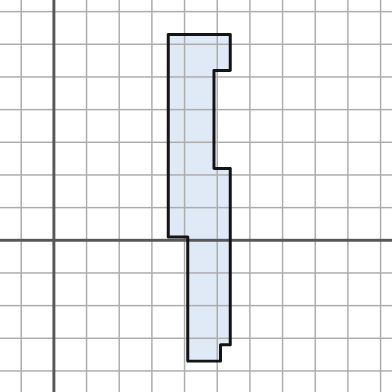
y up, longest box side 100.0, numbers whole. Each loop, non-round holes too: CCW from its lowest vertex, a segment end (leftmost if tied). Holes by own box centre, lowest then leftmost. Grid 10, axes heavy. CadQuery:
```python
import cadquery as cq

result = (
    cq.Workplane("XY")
    .moveTo(41.0, -37.0)
    .lineTo(51.0, -37.0)
    .lineTo(51.0, -32.0)
    .lineTo(54.0, -32.0)
    .lineTo(54.0, 22.0)
    .lineTo(49.0, 22.0)
    .lineTo(49.0, 52.0)
    .lineTo(54.0, 52.0)
    .lineTo(54.0, 63.0)
    .lineTo(35.0, 63.0)
    .lineTo(35.0, 1.0)
    .lineTo(41.0, 1.0)
    .close()
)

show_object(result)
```